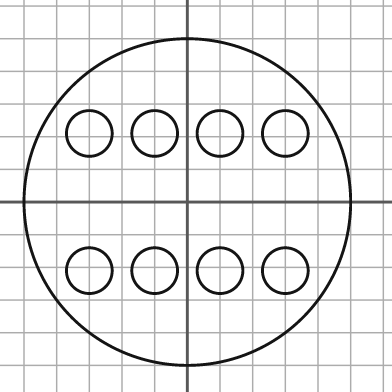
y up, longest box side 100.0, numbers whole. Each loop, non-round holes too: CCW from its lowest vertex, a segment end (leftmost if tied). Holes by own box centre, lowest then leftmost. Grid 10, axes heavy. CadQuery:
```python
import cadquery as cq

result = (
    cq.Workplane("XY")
    .moveTo(0.0, 0.0)
    .circle(50.0)
    .moveTo(-30.0, -21.0)
    .circle(7.0)
    .moveTo(-10.0, -21.0)
    .circle(7.0)
    .moveTo(10.0, -21.0)
    .circle(7.0)
    .moveTo(30.0, -21.0)
    .circle(7.0)
    .moveTo(-30.0, 21.0)
    .circle(7.0)
    .moveTo(-10.0, 21.0)
    .circle(7.0)
    .moveTo(10.0, 21.0)
    .circle(7.0)
    .moveTo(30.0, 21.0)
    .circle(7.0)
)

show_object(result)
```